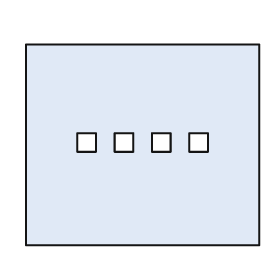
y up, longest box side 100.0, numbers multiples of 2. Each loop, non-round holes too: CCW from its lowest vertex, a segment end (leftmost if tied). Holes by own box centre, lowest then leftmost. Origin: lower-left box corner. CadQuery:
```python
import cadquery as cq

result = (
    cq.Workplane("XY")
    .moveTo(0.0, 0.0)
    .lineTo(100.0, 0.0)
    .lineTo(100.0, 86.0)
    .lineTo(0.0, 86.0)
    .close()
    .moveTo(22.0, 40.0)
    .lineTo(30.0, 40.0)
    .lineTo(30.0, 48.0)
    .lineTo(22.0, 48.0)
    .close()
    .moveTo(38.0, 40.0)
    .lineTo(46.0, 40.0)
    .lineTo(46.0, 48.0)
    .lineTo(38.0, 48.0)
    .close()
    .moveTo(54.0, 40.0)
    .lineTo(62.0, 40.0)
    .lineTo(62.0, 48.0)
    .lineTo(54.0, 48.0)
    .close()
    .moveTo(70.0, 40.0)
    .lineTo(78.0, 40.0)
    .lineTo(78.0, 48.0)
    .lineTo(70.0, 48.0)
    .close()
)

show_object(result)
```